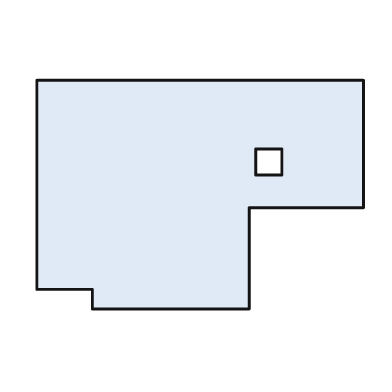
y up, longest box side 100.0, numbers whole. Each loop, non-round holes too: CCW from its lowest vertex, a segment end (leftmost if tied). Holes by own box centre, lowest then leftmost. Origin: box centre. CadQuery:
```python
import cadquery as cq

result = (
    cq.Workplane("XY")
    .moveTo(-33.0, -35.0)
    .lineTo(15.0, -35.0)
    .lineTo(15.0, -4.0)
    .lineTo(50.0, -4.0)
    .lineTo(50.0, 35.0)
    .lineTo(-50.0, 35.0)
    .lineTo(-50.0, -29.0)
    .lineTo(-33.0, -29.0)
    .close()
    .moveTo(17.0, 6.0)
    .lineTo(25.0, 6.0)
    .lineTo(25.0, 14.0)
    .lineTo(17.0, 14.0)
    .close()
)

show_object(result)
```